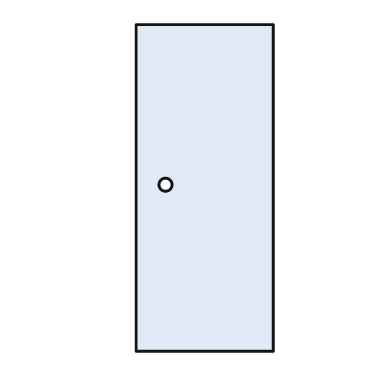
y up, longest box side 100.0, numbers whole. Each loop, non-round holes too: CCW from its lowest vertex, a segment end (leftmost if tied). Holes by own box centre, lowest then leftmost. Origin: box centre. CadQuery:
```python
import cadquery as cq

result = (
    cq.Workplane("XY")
    .moveTo(-21.0, -50.0)
    .lineTo(21.0, -50.0)
    .lineTo(21.0, 50.0)
    .lineTo(-21.0, 50.0)
    .close()
    .moveTo(-12.0, 1.0)
    .circle(2.0)
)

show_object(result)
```